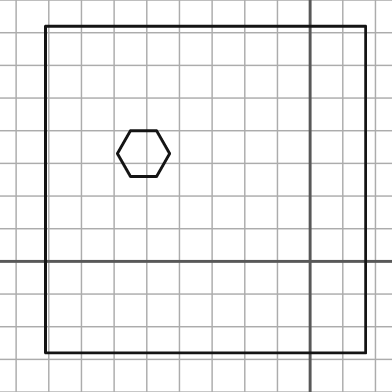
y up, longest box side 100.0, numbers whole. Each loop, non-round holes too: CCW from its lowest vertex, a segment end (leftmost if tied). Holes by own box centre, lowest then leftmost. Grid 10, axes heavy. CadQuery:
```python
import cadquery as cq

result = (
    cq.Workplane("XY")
    .moveTo(-81.0, -28.0)
    .lineTo(17.0, -28.0)
    .lineTo(17.0, 72.0)
    .lineTo(-81.0, 72.0)
    .close()
    .moveTo(-55.0, 26.0)
    .lineTo(-47.0, 26.0)
    .lineTo(-43.0, 33.0)
    .lineTo(-47.0, 40.0)
    .lineTo(-55.0, 40.0)
    .lineTo(-59.0, 33.0)
    .close()
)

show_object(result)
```